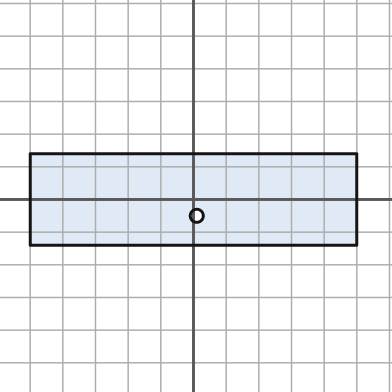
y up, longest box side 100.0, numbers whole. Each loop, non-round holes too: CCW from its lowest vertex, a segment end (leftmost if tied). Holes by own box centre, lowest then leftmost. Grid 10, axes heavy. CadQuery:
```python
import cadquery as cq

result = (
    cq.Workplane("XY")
    .moveTo(-50.0, -14.0)
    .lineTo(50.0, -14.0)
    .lineTo(50.0, 14.0)
    .lineTo(-50.0, 14.0)
    .close()
    .moveTo(1.0, -5.0)
    .circle(2.0)
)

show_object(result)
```